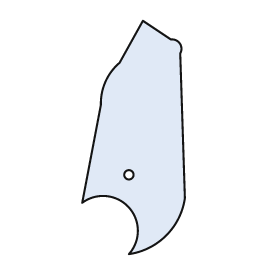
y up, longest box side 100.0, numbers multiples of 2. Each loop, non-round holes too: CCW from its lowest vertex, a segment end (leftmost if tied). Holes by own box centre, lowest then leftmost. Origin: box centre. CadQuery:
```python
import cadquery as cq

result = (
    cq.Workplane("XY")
    .moveTo(-2.0, -50.0)
    .threePointArc((14.0, -42.0), (22.0, -26.0))
    .lineTo(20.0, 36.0)
    .threePointArc((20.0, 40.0), (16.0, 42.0))
    .lineTo(4.0, 50.0)
    .lineTo(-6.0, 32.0)
    .threePointArc((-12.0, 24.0), (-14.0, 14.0))
    .lineTo(-22.0, -28.0)
    .threePointArc((-2.0, -30.0), (-2.0, -50.0))
    .close()
    .moveTo(-2.0, -16.0)
    .circle(2.0)
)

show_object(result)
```